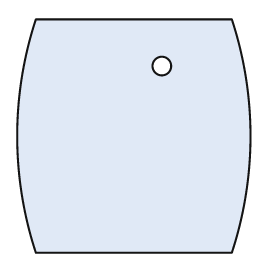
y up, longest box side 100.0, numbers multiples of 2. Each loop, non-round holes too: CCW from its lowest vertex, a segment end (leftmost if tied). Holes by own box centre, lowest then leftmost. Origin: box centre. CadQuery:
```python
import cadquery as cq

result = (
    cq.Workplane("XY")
    .moveTo(-42.0, -50.0)
    .lineTo(42.0, -50.0)
    .threePointArc((50.0, 0.0), (42.0, 50.0))
    .lineTo(-42.0, 50.0)
    .threePointArc((-50.0, 0.0), (-42.0, -50.0))
    .close()
    .moveTo(12.0, 30.0)
    .circle(4.0)
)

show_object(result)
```